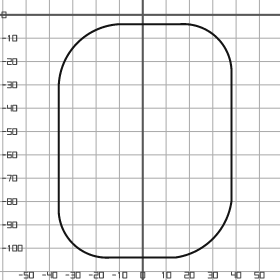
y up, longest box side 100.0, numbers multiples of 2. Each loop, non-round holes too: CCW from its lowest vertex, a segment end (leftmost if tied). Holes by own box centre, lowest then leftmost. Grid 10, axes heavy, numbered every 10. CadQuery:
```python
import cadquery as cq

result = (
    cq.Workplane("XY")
    .moveTo(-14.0, -104.0)
    .lineTo(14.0, -104.0)
    .threePointArc((30.0, -96.0), (38.0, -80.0))
    .lineTo(38.0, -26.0)
    .threePointArc((32.0, -10.0), (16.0, -4.0))
    .lineTo(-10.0, -4.0)
    .threePointArc((-28.0, -12.0), (-36.0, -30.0))
    .lineTo(-36.0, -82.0)
    .threePointArc((-30.0, -98.0), (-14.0, -104.0))
    .close()
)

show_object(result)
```